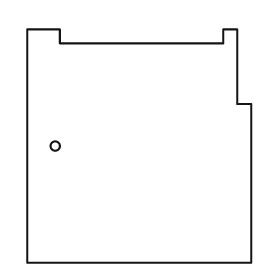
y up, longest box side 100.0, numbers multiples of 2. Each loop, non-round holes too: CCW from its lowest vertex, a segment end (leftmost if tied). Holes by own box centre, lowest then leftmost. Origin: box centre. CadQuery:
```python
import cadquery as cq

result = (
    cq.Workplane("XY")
    .moveTo(-48.0, -50.0)
    .lineTo(48.0, -50.0)
    .lineTo(48.0, 18.0)
    .lineTo(42.0, 18.0)
    .lineTo(42.0, 50.0)
    .lineTo(36.0, 50.0)
    .lineTo(36.0, 44.0)
    .lineTo(-34.0, 44.0)
    .lineTo(-34.0, 50.0)
    .lineTo(-48.0, 50.0)
    .close()
    .moveTo(-36.0, 0.0)
    .circle(2.0)
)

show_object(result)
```